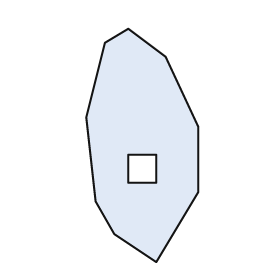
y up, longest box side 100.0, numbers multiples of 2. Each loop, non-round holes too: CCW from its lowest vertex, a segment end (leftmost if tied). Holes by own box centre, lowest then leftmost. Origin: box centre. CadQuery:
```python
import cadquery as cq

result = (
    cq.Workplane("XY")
    .moveTo(6.0, -50.0)
    .lineTo(24.0, -20.0)
    .lineTo(24.0, 8.0)
    .lineTo(10.0, 38.0)
    .lineTo(-6.0, 50.0)
    .lineTo(-16.0, 44.0)
    .lineTo(-24.0, 12.0)
    .lineTo(-20.0, -24.0)
    .lineTo(-12.0, -38.0)
    .close()
    .moveTo(-6.0, -16.0)
    .lineTo(6.0, -16.0)
    .lineTo(6.0, -4.0)
    .lineTo(-6.0, -4.0)
    .close()
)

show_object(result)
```